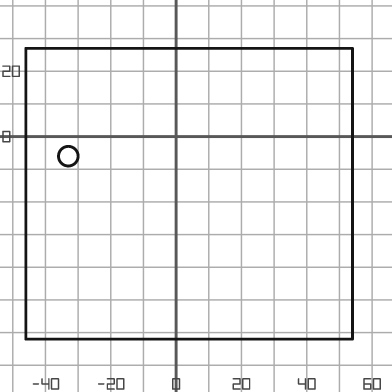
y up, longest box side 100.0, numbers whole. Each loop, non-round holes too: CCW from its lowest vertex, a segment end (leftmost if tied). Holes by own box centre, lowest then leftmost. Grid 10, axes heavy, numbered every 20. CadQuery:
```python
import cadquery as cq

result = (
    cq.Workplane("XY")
    .moveTo(-46.0, -62.0)
    .lineTo(54.0, -62.0)
    .lineTo(54.0, 27.0)
    .lineTo(-46.0, 27.0)
    .close()
    .moveTo(-33.0, -6.0)
    .circle(3.0)
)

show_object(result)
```